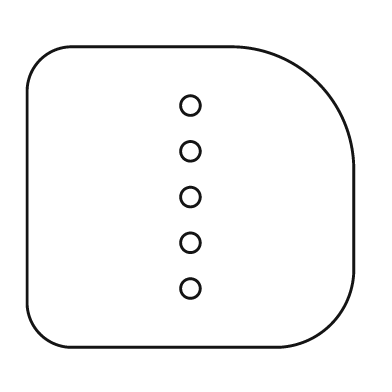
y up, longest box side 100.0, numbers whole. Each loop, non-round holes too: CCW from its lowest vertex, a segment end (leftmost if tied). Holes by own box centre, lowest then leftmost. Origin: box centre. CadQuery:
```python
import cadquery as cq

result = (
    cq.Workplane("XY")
    .moveTo(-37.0, -46.0)
    .lineTo(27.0, -46.0)
    .threePointArc((43.0, -39.0), (50.0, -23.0))
    .lineTo(50.0, 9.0)
    .threePointArc((39.0, 35.0), (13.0, 46.0))
    .lineTo(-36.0, 46.0)
    .threePointArc((-46.0, 42.0), (-50.0, 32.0))
    .lineTo(-50.0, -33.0)
    .threePointArc((-46.0, -42.0), (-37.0, -46.0))
    .close()
    .moveTo(0.0, -28.0)
    .circle(3.0)
    .moveTo(0.0, -14.0)
    .circle(3.0)
    .moveTo(0.0, 0.0)
    .circle(3.0)
    .moveTo(0.0, 14.0)
    .circle(3.0)
    .moveTo(0.0, 28.0)
    .circle(3.0)
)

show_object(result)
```